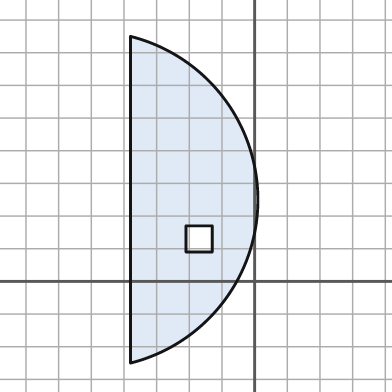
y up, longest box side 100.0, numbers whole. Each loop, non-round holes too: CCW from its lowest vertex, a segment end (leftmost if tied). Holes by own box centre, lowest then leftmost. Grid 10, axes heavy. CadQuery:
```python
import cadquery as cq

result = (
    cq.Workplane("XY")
    .moveTo(-38.0, -25.0)
    .threePointArc((1.0, 25.0), (-38.0, 75.0))
    .close()
    .moveTo(-21.0, 9.0)
    .lineTo(-13.0, 9.0)
    .lineTo(-13.0, 17.0)
    .lineTo(-21.0, 17.0)
    .close()
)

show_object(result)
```